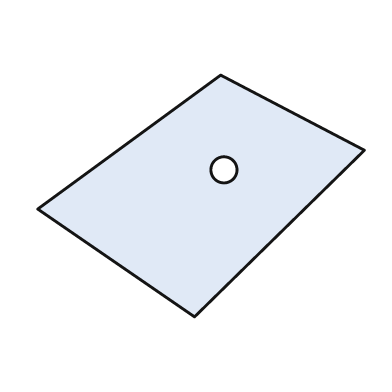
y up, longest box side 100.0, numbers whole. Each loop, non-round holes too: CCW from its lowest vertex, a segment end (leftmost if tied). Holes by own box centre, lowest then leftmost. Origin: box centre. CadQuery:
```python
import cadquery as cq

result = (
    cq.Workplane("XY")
    .moveTo(-2.0, -37.0)
    .lineTo(50.0, 14.0)
    .lineTo(6.0, 37.0)
    .lineTo(-50.0, -4.0)
    .close()
    .moveTo(7.0, 8.0)
    .circle(4.0)
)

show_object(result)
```